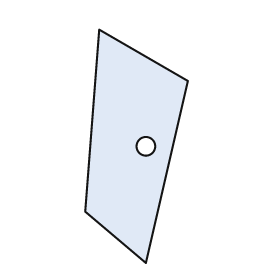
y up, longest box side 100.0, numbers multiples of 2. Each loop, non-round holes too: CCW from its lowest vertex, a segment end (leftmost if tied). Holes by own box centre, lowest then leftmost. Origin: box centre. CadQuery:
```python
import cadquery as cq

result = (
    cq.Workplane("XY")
    .moveTo(4.0, -50.0)
    .lineTo(22.0, 28.0)
    .lineTo(-16.0, 50.0)
    .lineTo(-22.0, -28.0)
    .close()
    .moveTo(4.0, 0.0)
    .circle(4.0)
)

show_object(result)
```